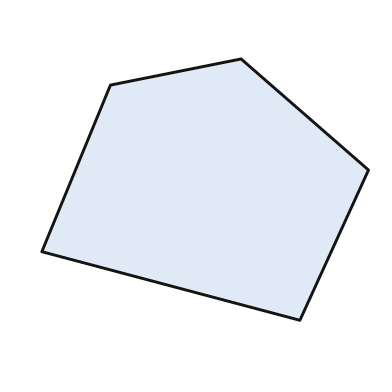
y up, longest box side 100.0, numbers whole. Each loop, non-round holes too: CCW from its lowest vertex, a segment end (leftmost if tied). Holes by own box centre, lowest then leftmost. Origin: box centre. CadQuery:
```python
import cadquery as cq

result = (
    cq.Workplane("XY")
    .moveTo(29.0, -40.0)
    .lineTo(50.0, 6.0)
    .lineTo(11.0, 40.0)
    .lineTo(-29.0, 32.0)
    .lineTo(-50.0, -19.0)
    .close()
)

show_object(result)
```